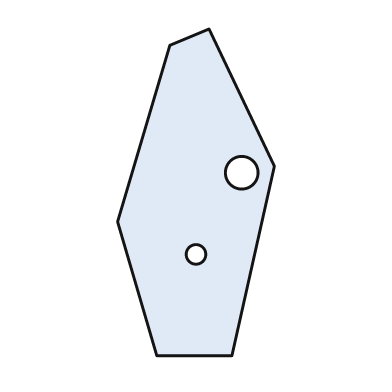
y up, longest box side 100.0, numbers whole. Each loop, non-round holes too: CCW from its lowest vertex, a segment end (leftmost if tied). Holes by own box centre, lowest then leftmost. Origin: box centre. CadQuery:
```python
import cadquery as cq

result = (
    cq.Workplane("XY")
    .moveTo(-12.0, -50.0)
    .lineTo(11.0, -50.0)
    .lineTo(24.0, 8.0)
    .lineTo(4.0, 50.0)
    .lineTo(-8.0, 45.0)
    .lineTo(-24.0, -9.0)
    .close()
    .moveTo(0.0, -19.0)
    .circle(3.0)
    .moveTo(14.0, 6.0)
    .circle(5.0)
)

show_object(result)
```